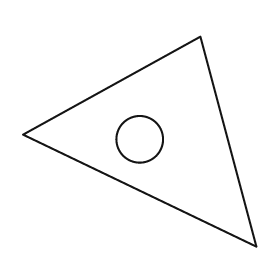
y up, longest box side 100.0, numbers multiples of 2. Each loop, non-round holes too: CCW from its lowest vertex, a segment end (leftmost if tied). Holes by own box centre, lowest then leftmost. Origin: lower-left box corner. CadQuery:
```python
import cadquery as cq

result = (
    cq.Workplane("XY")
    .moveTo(100.0, 0.0)
    .lineTo(76.0, 90.0)
    .lineTo(0.0, 48.0)
    .close()
    .moveTo(50.0, 46.0)
    .circle(10.0)
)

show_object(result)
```